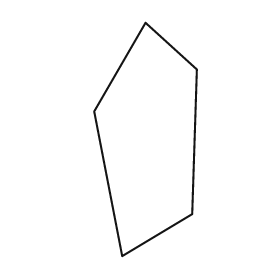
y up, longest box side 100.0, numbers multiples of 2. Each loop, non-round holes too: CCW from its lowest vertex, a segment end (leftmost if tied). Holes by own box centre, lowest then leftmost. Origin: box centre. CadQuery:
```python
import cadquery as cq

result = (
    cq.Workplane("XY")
    .moveTo(-10.0, -50.0)
    .lineTo(20.0, -32.0)
    .lineTo(22.0, 30.0)
    .lineTo(0.0, 50.0)
    .lineTo(-22.0, 12.0)
    .close()
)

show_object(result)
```